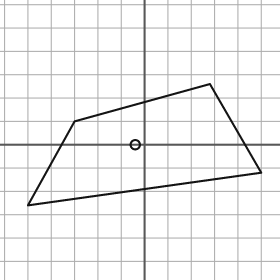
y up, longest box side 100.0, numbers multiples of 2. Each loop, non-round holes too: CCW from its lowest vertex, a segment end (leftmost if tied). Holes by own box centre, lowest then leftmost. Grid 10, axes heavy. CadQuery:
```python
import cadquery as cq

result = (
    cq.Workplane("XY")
    .moveTo(-50.0, -26.0)
    .lineTo(50.0, -12.0)
    .lineTo(28.0, 26.0)
    .lineTo(-30.0, 10.0)
    .close()
    .moveTo(-4.0, 0.0)
    .circle(2.0)
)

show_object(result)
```